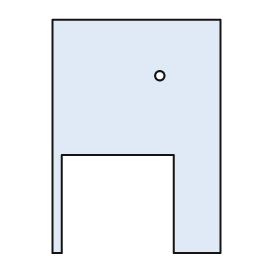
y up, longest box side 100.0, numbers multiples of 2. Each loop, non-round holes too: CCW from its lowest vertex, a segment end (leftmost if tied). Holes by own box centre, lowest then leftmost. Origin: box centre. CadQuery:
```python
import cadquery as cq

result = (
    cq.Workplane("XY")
    .moveTo(-36.0, -50.0)
    .lineTo(-32.0, -50.0)
    .lineTo(-32.0, -8.0)
    .lineTo(16.0, -8.0)
    .lineTo(16.0, -50.0)
    .lineTo(36.0, -50.0)
    .lineTo(36.0, 50.0)
    .lineTo(-36.0, 50.0)
    .close()
    .moveTo(10.0, 26.0)
    .circle(2.0)
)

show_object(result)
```